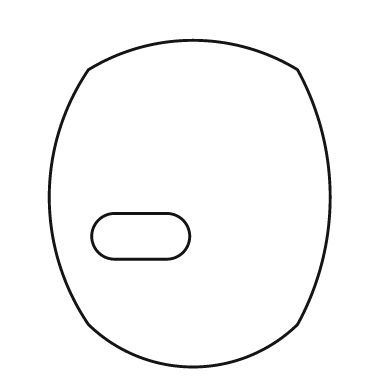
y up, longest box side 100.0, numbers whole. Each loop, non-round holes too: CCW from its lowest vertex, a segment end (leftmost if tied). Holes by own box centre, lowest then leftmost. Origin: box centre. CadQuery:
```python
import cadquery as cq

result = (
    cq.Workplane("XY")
    .moveTo(-31.0, -37.0)
    .threePointArc((1.0, -50.0), (33.0, -37.0))
    .threePointArc((43.0, 2.0), (33.0, 41.0))
    .threePointArc((1.0, 50.0), (-31.0, 41.0))
    .threePointArc((-43.0, 2.0), (-31.0, -37.0))
    .close()
    .moveTo(-23.0, -17.0)
    .lineTo(-7.0, -17.0)
    .threePointArc((0.0, -10.0), (-7.0, -3.0))
    .lineTo(-23.0, -3.0)
    .threePointArc((-30.0, -10.0), (-23.0, -17.0))
    .close()
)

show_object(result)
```